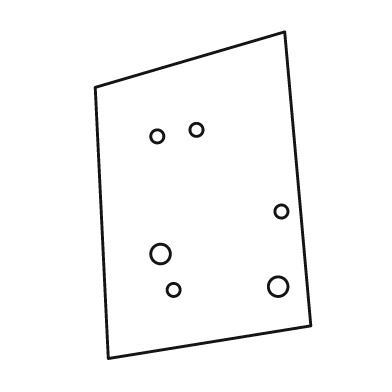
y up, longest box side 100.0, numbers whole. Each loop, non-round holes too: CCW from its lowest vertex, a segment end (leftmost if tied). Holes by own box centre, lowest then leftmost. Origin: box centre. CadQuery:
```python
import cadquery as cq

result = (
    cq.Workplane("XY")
    .moveTo(-29.0, -50.0)
    .lineTo(33.0, -40.0)
    .lineTo(25.0, 50.0)
    .lineTo(-33.0, 33.0)
    .close()
    .moveTo(-9.0, -29.0)
    .circle(2.0)
    .moveTo(23.0, -28.0)
    .circle(3.0)
    .moveTo(-13.0, -18.0)
    .circle(3.0)
    .moveTo(24.0, -5.0)
    .circle(2.0)
    .moveTo(-14.0, 18.0)
    .circle(2.0)
    .moveTo(-2.0, 20.0)
    .circle(2.0)
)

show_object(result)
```